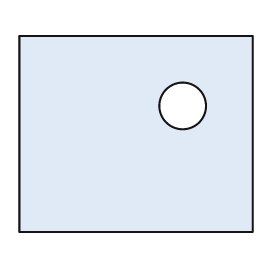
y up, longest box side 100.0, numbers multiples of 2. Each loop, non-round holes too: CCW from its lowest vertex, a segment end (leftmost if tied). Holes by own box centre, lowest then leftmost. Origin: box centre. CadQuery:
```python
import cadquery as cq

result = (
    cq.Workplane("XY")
    .moveTo(-50.0, -42.0)
    .lineTo(50.0, -42.0)
    .lineTo(50.0, 42.0)
    .lineTo(-50.0, 42.0)
    .close()
    .moveTo(20.0, 12.0)
    .circle(10.0)
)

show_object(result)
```